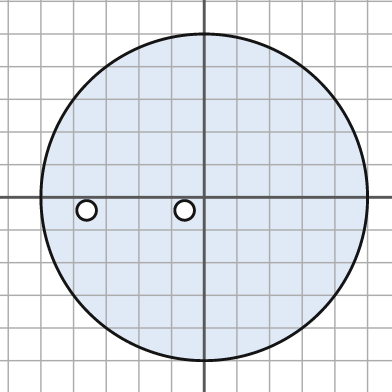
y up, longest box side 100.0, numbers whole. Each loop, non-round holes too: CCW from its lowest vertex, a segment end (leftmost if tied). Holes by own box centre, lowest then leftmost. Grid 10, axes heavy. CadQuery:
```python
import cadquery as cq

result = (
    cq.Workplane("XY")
    .moveTo(0.0, 0.0)
    .circle(50.0)
    .moveTo(-36.0, -4.0)
    .circle(3.0)
    .moveTo(-6.0, -4.0)
    .circle(3.0)
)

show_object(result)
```